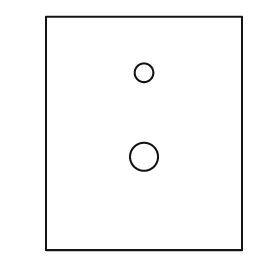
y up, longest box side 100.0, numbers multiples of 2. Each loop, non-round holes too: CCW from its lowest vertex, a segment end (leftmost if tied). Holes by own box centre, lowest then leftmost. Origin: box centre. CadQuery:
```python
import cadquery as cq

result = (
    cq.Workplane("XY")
    .moveTo(-42.0, -50.0)
    .lineTo(42.0, -50.0)
    .lineTo(42.0, 50.0)
    .lineTo(-42.0, 50.0)
    .close()
    .moveTo(0.0, -10.0)
    .circle(6.0)
    .moveTo(0.0, 26.0)
    .circle(4.0)
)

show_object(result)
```